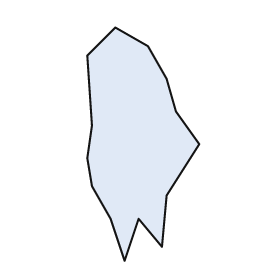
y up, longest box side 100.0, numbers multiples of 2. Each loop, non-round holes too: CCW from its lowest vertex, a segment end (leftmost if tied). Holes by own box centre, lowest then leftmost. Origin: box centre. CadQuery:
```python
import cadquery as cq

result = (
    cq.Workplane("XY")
    .moveTo(-8.0, -50.0)
    .lineTo(-2.0, -32.0)
    .lineTo(8.0, -44.0)
    .lineTo(10.0, -22.0)
    .lineTo(24.0, 0.0)
    .lineTo(14.0, 14.0)
    .lineTo(10.0, 28.0)
    .lineTo(2.0, 42.0)
    .lineTo(-12.0, 50.0)
    .lineTo(-24.0, 38.0)
    .lineTo(-22.0, 8.0)
    .lineTo(-24.0, -6.0)
    .lineTo(-22.0, -18.0)
    .lineTo(-14.0, -32.0)
    .close()
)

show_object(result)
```